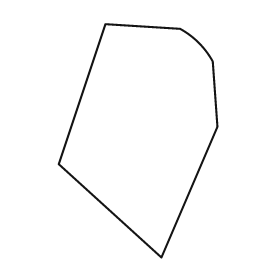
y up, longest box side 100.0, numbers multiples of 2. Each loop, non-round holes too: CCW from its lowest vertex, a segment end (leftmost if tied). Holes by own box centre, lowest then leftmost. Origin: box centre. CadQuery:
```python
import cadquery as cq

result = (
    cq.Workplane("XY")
    .moveTo(10.0, -50.0)
    .lineTo(34.0, 6.0)
    .lineTo(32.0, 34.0)
    .threePointArc((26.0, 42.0), (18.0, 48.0))
    .lineTo(-14.0, 50.0)
    .lineTo(-34.0, -10.0)
    .close()
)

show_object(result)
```